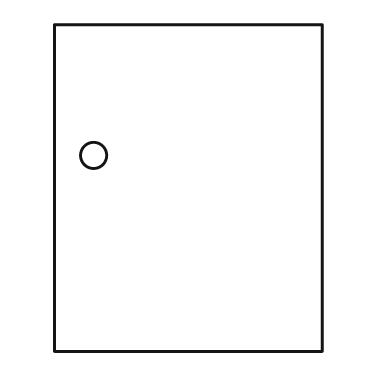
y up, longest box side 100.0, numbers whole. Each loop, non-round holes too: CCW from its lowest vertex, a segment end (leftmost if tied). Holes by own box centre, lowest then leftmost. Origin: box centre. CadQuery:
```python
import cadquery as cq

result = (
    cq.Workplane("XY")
    .moveTo(-41.0, -50.0)
    .lineTo(41.0, -50.0)
    .lineTo(41.0, 50.0)
    .lineTo(-41.0, 50.0)
    .close()
    .moveTo(-29.0, 10.0)
    .circle(4.0)
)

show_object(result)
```